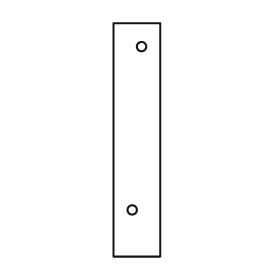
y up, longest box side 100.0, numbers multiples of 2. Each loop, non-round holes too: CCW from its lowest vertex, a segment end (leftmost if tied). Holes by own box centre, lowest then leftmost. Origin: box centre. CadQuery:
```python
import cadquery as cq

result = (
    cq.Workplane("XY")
    .moveTo(-10.0, -50.0)
    .lineTo(10.0, -50.0)
    .lineTo(10.0, 50.0)
    .lineTo(-10.0, 50.0)
    .close()
    .moveTo(-2.0, -30.0)
    .circle(2.0)
    .moveTo(2.0, 40.0)
    .circle(2.0)
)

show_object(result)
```